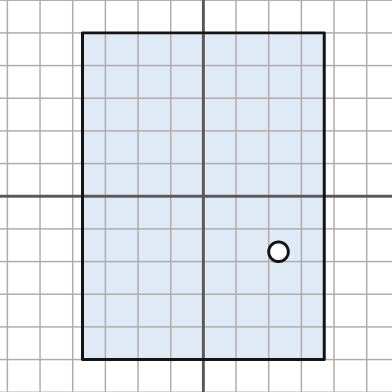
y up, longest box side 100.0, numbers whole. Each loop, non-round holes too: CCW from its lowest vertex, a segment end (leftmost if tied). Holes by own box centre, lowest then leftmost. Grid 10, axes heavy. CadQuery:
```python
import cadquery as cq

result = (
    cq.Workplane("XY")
    .moveTo(-37.0, -50.0)
    .lineTo(37.0, -50.0)
    .lineTo(37.0, 50.0)
    .lineTo(-37.0, 50.0)
    .close()
    .moveTo(23.0, -17.0)
    .circle(3.0)
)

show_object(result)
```